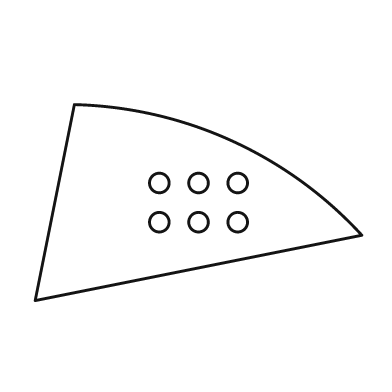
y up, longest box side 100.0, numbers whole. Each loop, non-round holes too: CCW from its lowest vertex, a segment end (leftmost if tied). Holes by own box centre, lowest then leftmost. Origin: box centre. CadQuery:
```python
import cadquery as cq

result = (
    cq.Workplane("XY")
    .moveTo(-50.0, -30.0)
    .lineTo(50.0, -10.0)
    .threePointArc((10.0, 19.0), (-38.0, 30.0))
    .close()
    .moveTo(-12.0, -6.0)
    .circle(3.0)
    .moveTo(0.0, -6.0)
    .circle(3.0)
    .moveTo(12.0, -6.0)
    .circle(3.0)
    .moveTo(-12.0, 6.0)
    .circle(3.0)
    .moveTo(0.0, 6.0)
    .circle(3.0)
    .moveTo(12.0, 6.0)
    .circle(3.0)
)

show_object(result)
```